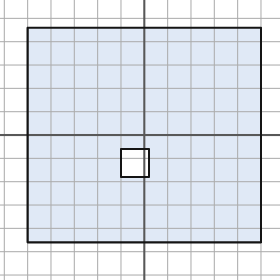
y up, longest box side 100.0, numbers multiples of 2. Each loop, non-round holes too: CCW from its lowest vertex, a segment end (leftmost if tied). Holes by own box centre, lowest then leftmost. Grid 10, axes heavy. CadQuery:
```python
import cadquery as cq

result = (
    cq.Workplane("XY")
    .moveTo(-50.0, -46.0)
    .lineTo(50.0, -46.0)
    .lineTo(50.0, 46.0)
    .lineTo(-50.0, 46.0)
    .close()
    .moveTo(-10.0, -18.0)
    .lineTo(2.0, -18.0)
    .lineTo(2.0, -6.0)
    .lineTo(-10.0, -6.0)
    .close()
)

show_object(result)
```